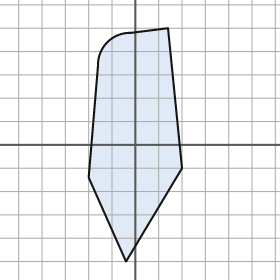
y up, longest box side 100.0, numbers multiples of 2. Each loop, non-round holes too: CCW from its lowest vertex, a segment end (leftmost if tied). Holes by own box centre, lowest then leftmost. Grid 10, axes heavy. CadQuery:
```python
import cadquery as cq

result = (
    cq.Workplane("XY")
    .moveTo(-4.0, -50.0)
    .lineTo(20.0, -10.0)
    .lineTo(14.0, 50.0)
    .lineTo(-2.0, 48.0)
    .threePointArc((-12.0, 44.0), (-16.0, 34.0))
    .lineTo(-20.0, -14.0)
    .close()
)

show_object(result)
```